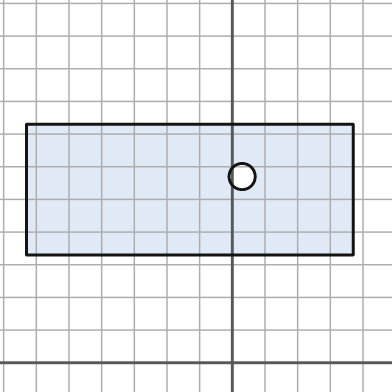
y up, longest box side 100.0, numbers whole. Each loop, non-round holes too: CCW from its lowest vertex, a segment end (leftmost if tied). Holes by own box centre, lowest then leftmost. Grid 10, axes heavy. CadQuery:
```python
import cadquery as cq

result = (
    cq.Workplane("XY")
    .moveTo(-63.0, 33.0)
    .lineTo(37.0, 33.0)
    .lineTo(37.0, 73.0)
    .lineTo(-63.0, 73.0)
    .close()
    .moveTo(3.0, 57.0)
    .circle(4.0)
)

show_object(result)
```